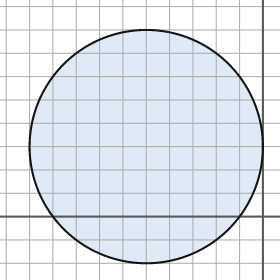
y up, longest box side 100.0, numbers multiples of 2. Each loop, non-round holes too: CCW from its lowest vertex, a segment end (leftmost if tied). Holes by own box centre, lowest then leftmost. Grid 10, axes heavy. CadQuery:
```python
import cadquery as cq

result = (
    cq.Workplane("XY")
    .moveTo(-50.0, 30.0)
    .circle(50.0)
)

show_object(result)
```